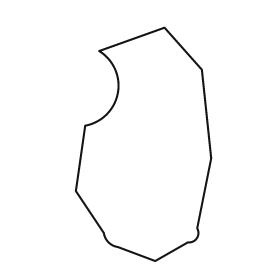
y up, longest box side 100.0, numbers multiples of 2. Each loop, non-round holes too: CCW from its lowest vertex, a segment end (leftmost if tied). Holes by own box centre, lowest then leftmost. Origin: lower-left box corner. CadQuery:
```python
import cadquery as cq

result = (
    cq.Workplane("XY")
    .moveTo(34.0, 0.0)
    .lineTo(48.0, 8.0)
    .threePointArc((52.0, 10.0), (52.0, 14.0))
    .lineTo(58.0, 44.0)
    .lineTo(54.0, 82.0)
    .lineTo(38.0, 100.0)
    .lineTo(10.0, 90.0)
    .threePointArc((18.0, 72.0), (4.0, 58.0))
    .lineTo(0.0, 30.0)
    .lineTo(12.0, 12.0)
    .threePointArc((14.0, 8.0), (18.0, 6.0))
    .close()
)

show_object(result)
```